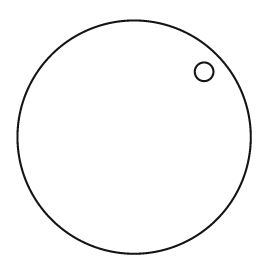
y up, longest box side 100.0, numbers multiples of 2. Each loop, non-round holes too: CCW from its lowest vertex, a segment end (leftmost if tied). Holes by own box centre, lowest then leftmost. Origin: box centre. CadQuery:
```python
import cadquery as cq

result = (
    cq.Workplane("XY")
    .moveTo(0.0, 0.0)
    .circle(50.0)
    .moveTo(30.0, 28.0)
    .circle(4.0)
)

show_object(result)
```